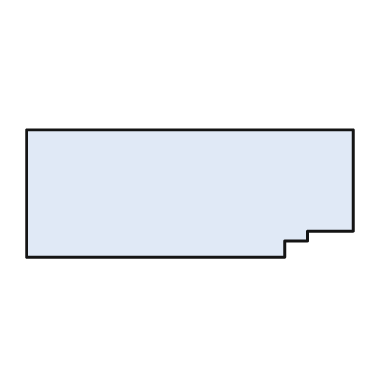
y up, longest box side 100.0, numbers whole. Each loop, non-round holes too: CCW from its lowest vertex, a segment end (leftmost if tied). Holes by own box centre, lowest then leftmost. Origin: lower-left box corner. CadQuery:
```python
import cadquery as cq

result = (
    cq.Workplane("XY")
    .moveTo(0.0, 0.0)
    .lineTo(79.0, 0.0)
    .lineTo(79.0, 5.0)
    .lineTo(86.0, 5.0)
    .lineTo(86.0, 8.0)
    .lineTo(100.0, 8.0)
    .lineTo(100.0, 39.0)
    .lineTo(0.0, 39.0)
    .close()
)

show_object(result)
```